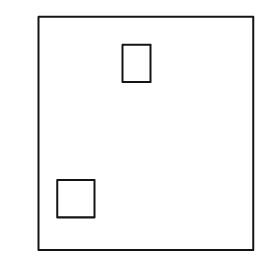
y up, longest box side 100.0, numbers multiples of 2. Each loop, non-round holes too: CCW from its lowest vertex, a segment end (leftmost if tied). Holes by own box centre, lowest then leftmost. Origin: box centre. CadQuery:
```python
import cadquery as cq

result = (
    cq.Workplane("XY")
    .moveTo(-46.0, -50.0)
    .lineTo(46.0, -50.0)
    .lineTo(46.0, 50.0)
    .lineTo(-46.0, 50.0)
    .close()
    .moveTo(-38.0, -36.0)
    .lineTo(-22.0, -36.0)
    .lineTo(-22.0, -20.0)
    .lineTo(-38.0, -20.0)
    .close()
    .moveTo(-10.0, 22.0)
    .lineTo(2.0, 22.0)
    .lineTo(2.0, 38.0)
    .lineTo(-10.0, 38.0)
    .close()
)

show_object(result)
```